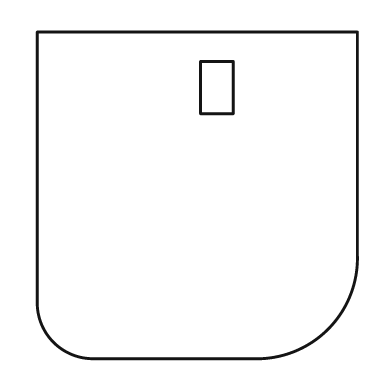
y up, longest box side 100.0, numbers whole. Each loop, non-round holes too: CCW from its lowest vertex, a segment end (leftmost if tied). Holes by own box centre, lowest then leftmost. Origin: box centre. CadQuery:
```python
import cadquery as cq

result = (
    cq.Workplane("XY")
    .moveTo(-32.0, -50.0)
    .lineTo(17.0, -50.0)
    .threePointArc((40.0, -41.0), (49.0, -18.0))
    .lineTo(49.0, 50.0)
    .lineTo(-49.0, 50.0)
    .lineTo(-49.0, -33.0)
    .threePointArc((-44.0, -45.0), (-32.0, -50.0))
    .close()
    .moveTo(1.0, 25.0)
    .lineTo(11.0, 25.0)
    .lineTo(11.0, 41.0)
    .lineTo(1.0, 41.0)
    .close()
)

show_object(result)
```